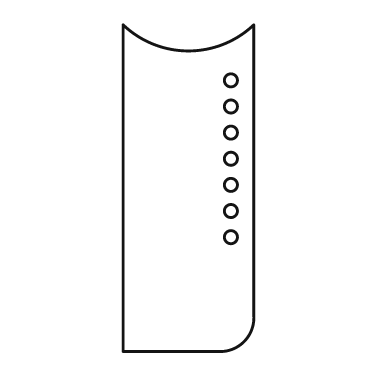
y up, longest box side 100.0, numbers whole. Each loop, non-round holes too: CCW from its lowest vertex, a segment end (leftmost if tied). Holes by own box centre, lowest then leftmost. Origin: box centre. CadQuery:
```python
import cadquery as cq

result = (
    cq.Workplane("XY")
    .moveTo(-20.0, -50.0)
    .lineTo(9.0, -50.0)
    .threePointArc((17.0, -47.0), (20.0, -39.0))
    .lineTo(20.0, 50.0)
    .threePointArc((0.0, 42.0), (-20.0, 50.0))
    .close()
    .moveTo(13.0, -15.0)
    .circle(2.0)
    .moveTo(13.0, -7.0)
    .circle(2.0)
    .moveTo(13.0, 1.0)
    .circle(2.0)
    .moveTo(13.0, 9.0)
    .circle(2.0)
    .moveTo(13.0, 17.0)
    .circle(2.0)
    .moveTo(13.0, 25.0)
    .circle(2.0)
    .moveTo(13.0, 33.0)
    .circle(2.0)
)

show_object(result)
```